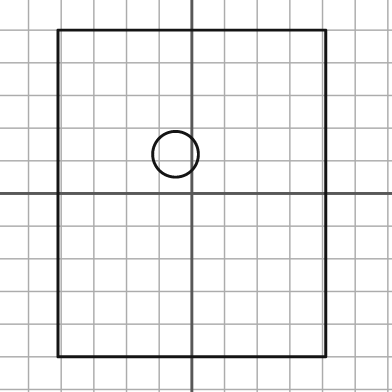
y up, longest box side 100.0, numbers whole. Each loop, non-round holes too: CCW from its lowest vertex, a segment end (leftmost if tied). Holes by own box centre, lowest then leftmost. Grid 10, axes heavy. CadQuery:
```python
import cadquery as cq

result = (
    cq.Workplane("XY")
    .moveTo(-41.0, -50.0)
    .lineTo(41.0, -50.0)
    .lineTo(41.0, 50.0)
    .lineTo(-41.0, 50.0)
    .close()
    .moveTo(-5.0, 12.0)
    .circle(7.0)
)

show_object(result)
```